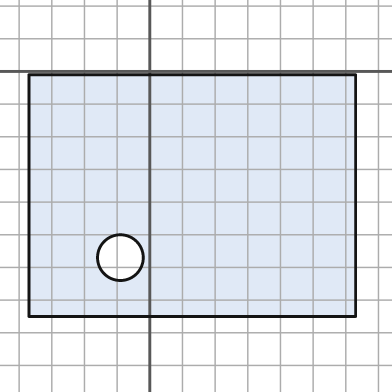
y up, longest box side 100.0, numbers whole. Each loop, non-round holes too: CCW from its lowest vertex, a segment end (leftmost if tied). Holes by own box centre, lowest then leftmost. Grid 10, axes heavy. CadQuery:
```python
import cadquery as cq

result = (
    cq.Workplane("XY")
    .moveTo(-37.0, -75.0)
    .lineTo(63.0, -75.0)
    .lineTo(63.0, -1.0)
    .lineTo(-37.0, -1.0)
    .close()
    .moveTo(-9.0, -57.0)
    .circle(7.0)
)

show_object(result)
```